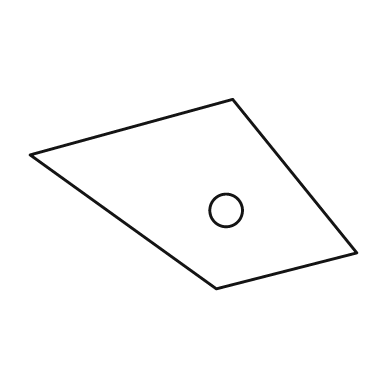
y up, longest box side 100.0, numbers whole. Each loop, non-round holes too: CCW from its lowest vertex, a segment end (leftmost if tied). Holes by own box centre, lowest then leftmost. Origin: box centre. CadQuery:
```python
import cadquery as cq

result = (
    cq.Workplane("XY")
    .moveTo(7.0, -29.0)
    .lineTo(50.0, -18.0)
    .lineTo(12.0, 29.0)
    .lineTo(-50.0, 12.0)
    .close()
    .moveTo(10.0, -5.0)
    .circle(5.0)
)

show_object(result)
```